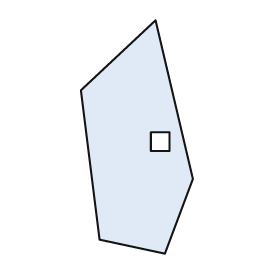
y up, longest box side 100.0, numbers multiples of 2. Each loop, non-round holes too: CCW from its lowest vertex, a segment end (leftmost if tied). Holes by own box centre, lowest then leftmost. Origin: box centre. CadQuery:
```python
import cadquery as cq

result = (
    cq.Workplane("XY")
    .moveTo(12.0, -50.0)
    .lineTo(24.0, -18.0)
    .lineTo(8.0, 50.0)
    .lineTo(-24.0, 20.0)
    .lineTo(-16.0, -44.0)
    .close()
    .moveTo(6.0, -6.0)
    .lineTo(14.0, -6.0)
    .lineTo(14.0, 2.0)
    .lineTo(6.0, 2.0)
    .close()
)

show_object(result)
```